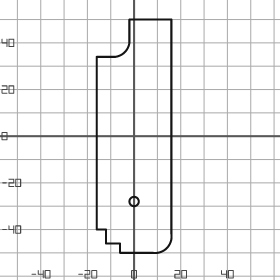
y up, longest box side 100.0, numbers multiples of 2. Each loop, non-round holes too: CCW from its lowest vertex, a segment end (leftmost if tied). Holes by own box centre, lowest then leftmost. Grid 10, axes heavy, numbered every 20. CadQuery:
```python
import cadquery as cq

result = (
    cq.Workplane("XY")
    .moveTo(-6.0, -50.0)
    .lineTo(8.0, -50.0)
    .threePointArc((14.0, -48.0), (16.0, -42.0))
    .lineTo(16.0, 50.0)
    .lineTo(-2.0, 50.0)
    .lineTo(-2.0, 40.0)
    .threePointArc((-4.0, 36.0), (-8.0, 34.0))
    .lineTo(-16.0, 34.0)
    .lineTo(-16.0, -40.0)
    .lineTo(-12.0, -40.0)
    .lineTo(-12.0, -46.0)
    .lineTo(-6.0, -46.0)
    .close()
    .moveTo(0.0, -28.0)
    .circle(2.0)
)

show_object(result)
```